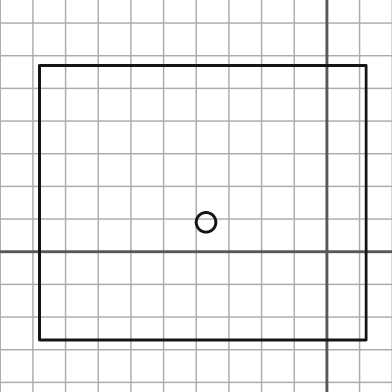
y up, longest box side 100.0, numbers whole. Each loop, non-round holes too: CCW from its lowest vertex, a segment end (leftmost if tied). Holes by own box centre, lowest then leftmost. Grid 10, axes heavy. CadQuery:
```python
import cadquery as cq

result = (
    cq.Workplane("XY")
    .moveTo(-88.0, -27.0)
    .lineTo(12.0, -27.0)
    .lineTo(12.0, 57.0)
    .lineTo(-88.0, 57.0)
    .close()
    .moveTo(-37.0, 9.0)
    .circle(3.0)
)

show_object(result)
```